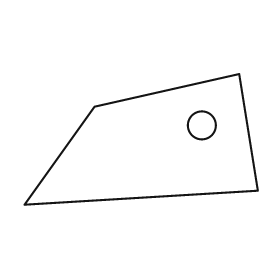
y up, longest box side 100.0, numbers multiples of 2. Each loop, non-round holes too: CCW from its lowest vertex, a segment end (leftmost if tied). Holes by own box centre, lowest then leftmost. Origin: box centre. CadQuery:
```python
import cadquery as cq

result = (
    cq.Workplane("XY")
    .moveTo(-50.0, -28.0)
    .lineTo(50.0, -22.0)
    .lineTo(42.0, 28.0)
    .lineTo(-20.0, 14.0)
    .close()
    .moveTo(26.0, 6.0)
    .circle(6.0)
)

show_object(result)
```